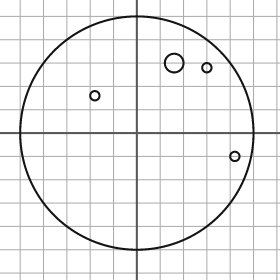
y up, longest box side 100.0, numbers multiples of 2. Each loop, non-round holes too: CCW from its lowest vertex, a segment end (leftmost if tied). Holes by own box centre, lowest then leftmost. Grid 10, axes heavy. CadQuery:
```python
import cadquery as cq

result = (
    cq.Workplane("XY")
    .moveTo(0.0, 0.0)
    .circle(50.0)
    .moveTo(42.0, -10.0)
    .circle(2.0)
    .moveTo(-18.0, 16.0)
    .circle(2.0)
    .moveTo(30.0, 28.0)
    .circle(2.0)
    .moveTo(16.0, 30.0)
    .circle(4.0)
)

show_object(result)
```